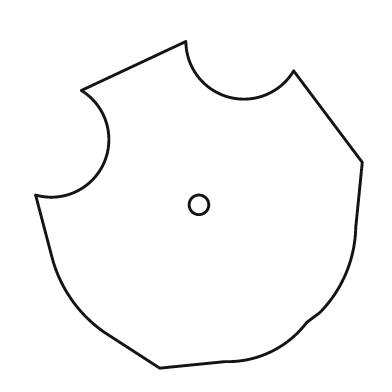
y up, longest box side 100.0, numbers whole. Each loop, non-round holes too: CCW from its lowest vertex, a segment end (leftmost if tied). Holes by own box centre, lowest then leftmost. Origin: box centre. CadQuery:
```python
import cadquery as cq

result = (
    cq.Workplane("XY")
    .moveTo(-12.0, -50.0)
    .lineTo(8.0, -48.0)
    .threePointArc((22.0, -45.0), (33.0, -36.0))
    .lineTo(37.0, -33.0)
    .threePointArc((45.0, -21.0), (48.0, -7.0))
    .lineTo(50.0, 13.0)
    .lineTo(29.0, 41.0)
    .threePointArc((9.0, 33.0), (-4.0, 50.0))
    .lineTo(-36.0, 35.0)
    .threePointArc((-29.0, 13.0), (-50.0, 3.0))
    .lineTo(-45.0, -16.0)
    .threePointArc((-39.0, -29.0), (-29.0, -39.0))
    .close()
    .moveTo(0.0, 0.0)
    .circle(3.0)
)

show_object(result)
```